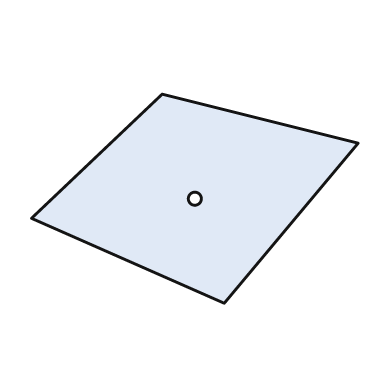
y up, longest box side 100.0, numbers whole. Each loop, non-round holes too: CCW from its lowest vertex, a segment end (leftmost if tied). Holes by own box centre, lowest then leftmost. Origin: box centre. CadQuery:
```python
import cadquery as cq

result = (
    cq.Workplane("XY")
    .moveTo(9.0, -32.0)
    .lineTo(50.0, 17.0)
    .lineTo(-10.0, 32.0)
    .lineTo(-50.0, -6.0)
    .close()
    .moveTo(0.0, 0.0)
    .circle(2.0)
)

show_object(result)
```